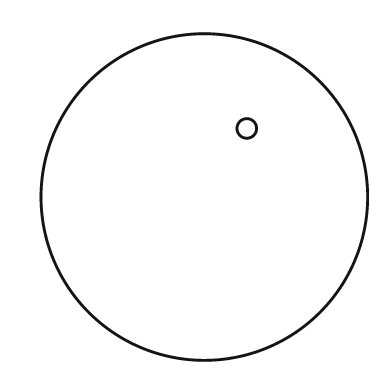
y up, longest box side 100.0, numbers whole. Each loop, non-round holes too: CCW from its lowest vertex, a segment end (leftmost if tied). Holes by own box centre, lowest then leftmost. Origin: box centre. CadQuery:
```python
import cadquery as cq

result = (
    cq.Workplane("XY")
    .moveTo(0.0, 0.0)
    .circle(50.0)
    .moveTo(13.0, 21.0)
    .circle(3.0)
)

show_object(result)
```